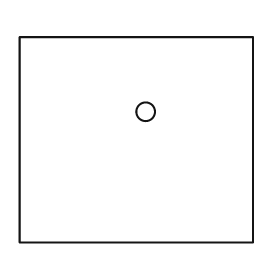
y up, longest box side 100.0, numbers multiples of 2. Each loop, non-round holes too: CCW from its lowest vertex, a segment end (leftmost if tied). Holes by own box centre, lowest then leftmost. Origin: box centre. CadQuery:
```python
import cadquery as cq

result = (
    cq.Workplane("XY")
    .moveTo(-50.0, -44.0)
    .lineTo(50.0, -44.0)
    .lineTo(50.0, 44.0)
    .lineTo(-50.0, 44.0)
    .close()
    .moveTo(4.0, 12.0)
    .circle(4.0)
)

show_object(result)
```